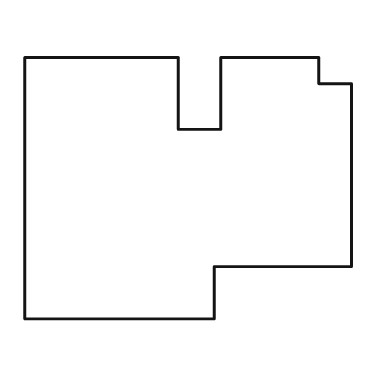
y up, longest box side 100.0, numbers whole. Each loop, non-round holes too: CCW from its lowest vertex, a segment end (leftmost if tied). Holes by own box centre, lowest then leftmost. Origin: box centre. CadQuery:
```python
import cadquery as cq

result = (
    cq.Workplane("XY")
    .moveTo(-50.0, -40.0)
    .lineTo(8.0, -40.0)
    .lineTo(8.0, -24.0)
    .lineTo(50.0, -24.0)
    .lineTo(50.0, 32.0)
    .lineTo(40.0, 32.0)
    .lineTo(40.0, 40.0)
    .lineTo(10.0, 40.0)
    .lineTo(10.0, 18.0)
    .lineTo(-3.0, 18.0)
    .lineTo(-3.0, 40.0)
    .lineTo(-50.0, 40.0)
    .close()
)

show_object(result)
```